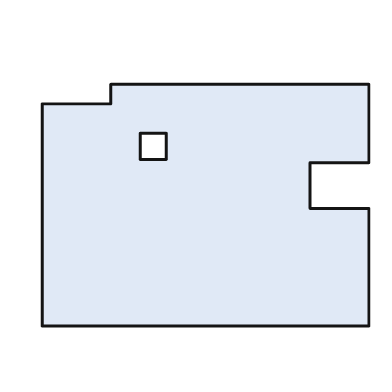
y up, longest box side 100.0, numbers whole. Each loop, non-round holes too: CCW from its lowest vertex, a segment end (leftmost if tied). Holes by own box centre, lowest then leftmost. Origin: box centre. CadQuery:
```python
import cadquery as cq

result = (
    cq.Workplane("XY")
    .moveTo(-50.0, -37.0)
    .lineTo(50.0, -37.0)
    .lineTo(50.0, -1.0)
    .lineTo(32.0, -1.0)
    .lineTo(32.0, 13.0)
    .lineTo(50.0, 13.0)
    .lineTo(50.0, 37.0)
    .lineTo(-29.0, 37.0)
    .lineTo(-29.0, 31.0)
    .lineTo(-50.0, 31.0)
    .close()
    .moveTo(-20.0, 14.0)
    .lineTo(-12.0, 14.0)
    .lineTo(-12.0, 22.0)
    .lineTo(-20.0, 22.0)
    .close()
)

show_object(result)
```